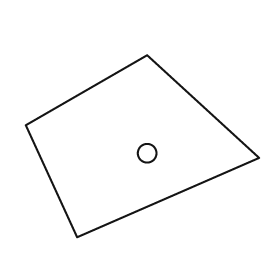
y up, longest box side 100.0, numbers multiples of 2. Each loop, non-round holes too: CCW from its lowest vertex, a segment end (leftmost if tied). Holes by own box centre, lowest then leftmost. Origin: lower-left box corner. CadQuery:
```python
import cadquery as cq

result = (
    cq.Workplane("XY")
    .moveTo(22.0, 0.0)
    .lineTo(100.0, 34.0)
    .lineTo(52.0, 78.0)
    .lineTo(0.0, 48.0)
    .close()
    .moveTo(52.0, 36.0)
    .circle(4.0)
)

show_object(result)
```